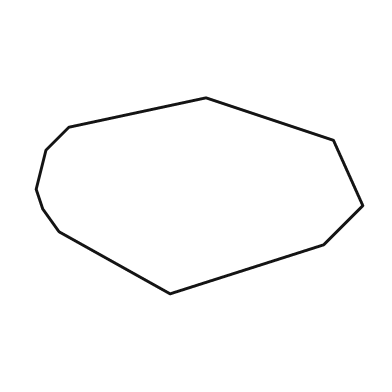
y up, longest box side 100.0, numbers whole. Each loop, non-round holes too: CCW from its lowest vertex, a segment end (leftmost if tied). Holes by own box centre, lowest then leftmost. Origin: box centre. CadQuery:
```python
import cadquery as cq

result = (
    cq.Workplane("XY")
    .moveTo(-9.0, -30.0)
    .lineTo(38.0, -15.0)
    .lineTo(50.0, -3.0)
    .lineTo(41.0, 17.0)
    .lineTo(2.0, 30.0)
    .lineTo(-40.0, 21.0)
    .lineTo(-47.0, 14.0)
    .lineTo(-50.0, 2.0)
    .lineTo(-48.0, -4.0)
    .lineTo(-43.0, -11.0)
    .close()
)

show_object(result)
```